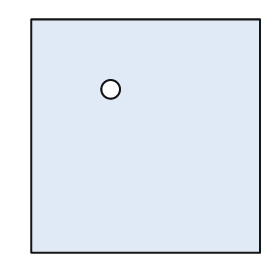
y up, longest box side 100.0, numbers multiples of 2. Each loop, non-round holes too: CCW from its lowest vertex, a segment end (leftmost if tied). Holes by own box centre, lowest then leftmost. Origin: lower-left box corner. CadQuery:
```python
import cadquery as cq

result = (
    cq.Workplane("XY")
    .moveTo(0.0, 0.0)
    .lineTo(98.0, 0.0)
    .lineTo(98.0, 100.0)
    .lineTo(0.0, 100.0)
    .close()
    .moveTo(34.0, 70.0)
    .circle(4.0)
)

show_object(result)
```